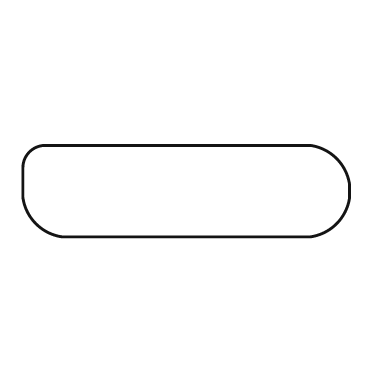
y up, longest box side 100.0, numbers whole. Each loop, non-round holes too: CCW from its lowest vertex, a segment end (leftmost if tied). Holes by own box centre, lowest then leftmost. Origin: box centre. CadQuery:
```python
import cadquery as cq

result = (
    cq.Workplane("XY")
    .moveTo(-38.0, -14.0)
    .lineTo(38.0, -14.0)
    .threePointArc((46.0, -10.0), (50.0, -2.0))
    .lineTo(50.0, 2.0)
    .threePointArc((46.0, 10.0), (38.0, 14.0))
    .lineTo(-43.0, 14.0)
    .threePointArc((-48.0, 12.0), (-50.0, 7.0))
    .lineTo(-50.0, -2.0)
    .threePointArc((-46.0, -10.0), (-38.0, -14.0))
    .close()
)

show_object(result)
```